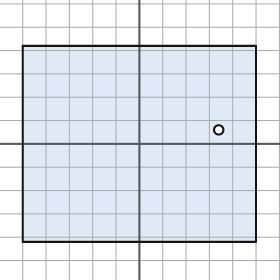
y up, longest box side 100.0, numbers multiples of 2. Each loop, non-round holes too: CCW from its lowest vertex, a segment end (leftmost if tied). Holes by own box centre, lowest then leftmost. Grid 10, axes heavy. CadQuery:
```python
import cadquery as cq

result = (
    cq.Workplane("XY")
    .moveTo(-50.0, -42.0)
    .lineTo(50.0, -42.0)
    .lineTo(50.0, 42.0)
    .lineTo(-50.0, 42.0)
    .close()
    .moveTo(34.0, 6.0)
    .circle(2.0)
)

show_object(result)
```